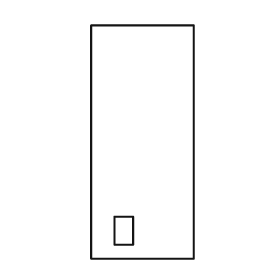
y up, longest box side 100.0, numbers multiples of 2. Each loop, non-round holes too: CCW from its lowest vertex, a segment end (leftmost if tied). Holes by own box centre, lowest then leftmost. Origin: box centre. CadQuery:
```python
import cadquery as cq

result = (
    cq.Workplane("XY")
    .moveTo(-22.0, -50.0)
    .lineTo(22.0, -50.0)
    .lineTo(22.0, 50.0)
    .lineTo(-22.0, 50.0)
    .close()
    .moveTo(-12.0, -44.0)
    .lineTo(-4.0, -44.0)
    .lineTo(-4.0, -32.0)
    .lineTo(-12.0, -32.0)
    .close()
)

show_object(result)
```